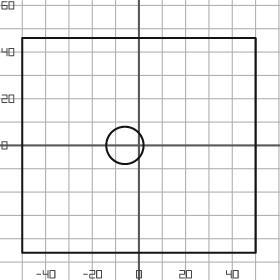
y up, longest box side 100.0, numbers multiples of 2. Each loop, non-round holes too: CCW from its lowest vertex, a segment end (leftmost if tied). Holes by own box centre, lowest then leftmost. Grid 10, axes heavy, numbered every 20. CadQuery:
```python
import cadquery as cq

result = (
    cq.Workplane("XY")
    .moveTo(-50.0, -46.0)
    .lineTo(50.0, -46.0)
    .lineTo(50.0, 46.0)
    .lineTo(-50.0, 46.0)
    .close()
    .moveTo(-6.0, 0.0)
    .circle(8.0)
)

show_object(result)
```